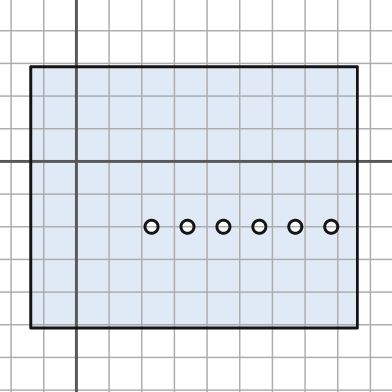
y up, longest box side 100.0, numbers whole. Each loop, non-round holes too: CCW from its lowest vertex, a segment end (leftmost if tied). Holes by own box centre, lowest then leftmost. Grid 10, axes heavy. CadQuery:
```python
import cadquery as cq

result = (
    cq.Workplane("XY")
    .moveTo(-14.0, -51.0)
    .lineTo(86.0, -51.0)
    .lineTo(86.0, 29.0)
    .lineTo(-14.0, 29.0)
    .close()
    .moveTo(23.0, -20.0)
    .circle(2.0)
    .moveTo(34.0, -20.0)
    .circle(2.0)
    .moveTo(45.0, -20.0)
    .circle(2.0)
    .moveTo(56.0, -20.0)
    .circle(2.0)
    .moveTo(67.0, -20.0)
    .circle(2.0)
    .moveTo(78.0, -20.0)
    .circle(2.0)
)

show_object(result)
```